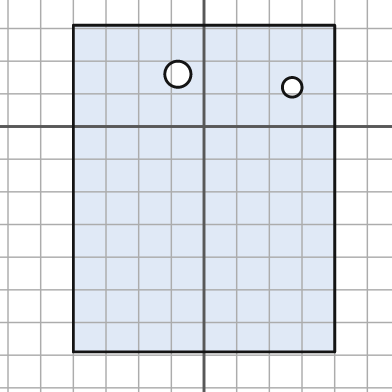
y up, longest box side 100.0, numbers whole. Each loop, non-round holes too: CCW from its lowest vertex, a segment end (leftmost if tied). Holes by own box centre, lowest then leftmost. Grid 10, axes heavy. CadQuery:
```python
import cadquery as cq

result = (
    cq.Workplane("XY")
    .moveTo(-40.0, -69.0)
    .lineTo(40.0, -69.0)
    .lineTo(40.0, 31.0)
    .lineTo(-40.0, 31.0)
    .close()
    .moveTo(27.0, 12.0)
    .circle(3.0)
    .moveTo(-8.0, 16.0)
    .circle(4.0)
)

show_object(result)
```